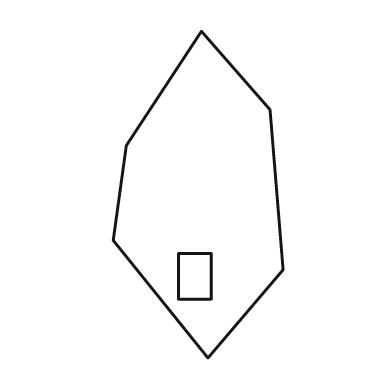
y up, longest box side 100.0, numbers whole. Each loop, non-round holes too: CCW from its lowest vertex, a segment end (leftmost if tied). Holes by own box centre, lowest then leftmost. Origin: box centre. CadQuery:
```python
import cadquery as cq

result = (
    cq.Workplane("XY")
    .moveTo(3.0, -50.0)
    .lineTo(26.0, -23.0)
    .lineTo(22.0, 26.0)
    .lineTo(1.0, 50.0)
    .lineTo(-22.0, 15.0)
    .lineTo(-26.0, -14.0)
    .close()
    .moveTo(-6.0, -32.0)
    .lineTo(4.0, -32.0)
    .lineTo(4.0, -18.0)
    .lineTo(-6.0, -18.0)
    .close()
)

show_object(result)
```